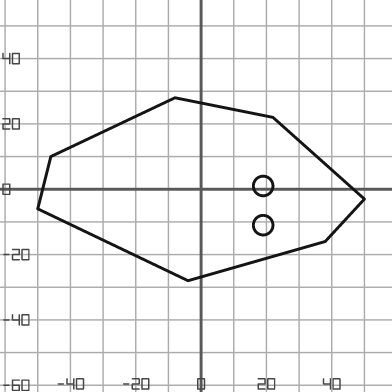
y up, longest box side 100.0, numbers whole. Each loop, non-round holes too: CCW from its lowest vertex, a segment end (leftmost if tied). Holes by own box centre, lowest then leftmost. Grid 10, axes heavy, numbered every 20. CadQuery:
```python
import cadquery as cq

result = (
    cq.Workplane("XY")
    .moveTo(-4.0, -28.0)
    .lineTo(38.0, -16.0)
    .lineTo(50.0, -3.0)
    .lineTo(22.0, 22.0)
    .lineTo(-8.0, 28.0)
    .lineTo(-46.0, 10.0)
    .lineTo(-50.0, -6.0)
    .close()
    .moveTo(19.0, -11.0)
    .circle(3.0)
    .moveTo(19.0, 1.0)
    .circle(3.0)
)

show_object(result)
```